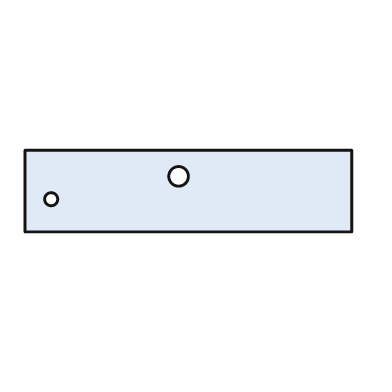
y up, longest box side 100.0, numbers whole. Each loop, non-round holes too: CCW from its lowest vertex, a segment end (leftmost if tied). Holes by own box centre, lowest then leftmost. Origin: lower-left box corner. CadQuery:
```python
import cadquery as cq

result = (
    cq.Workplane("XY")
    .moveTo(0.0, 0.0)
    .lineTo(100.0, 0.0)
    .lineTo(100.0, 25.0)
    .lineTo(0.0, 25.0)
    .close()
    .moveTo(8.0, 10.0)
    .circle(2.0)
    .moveTo(47.0, 17.0)
    .circle(3.0)
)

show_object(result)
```